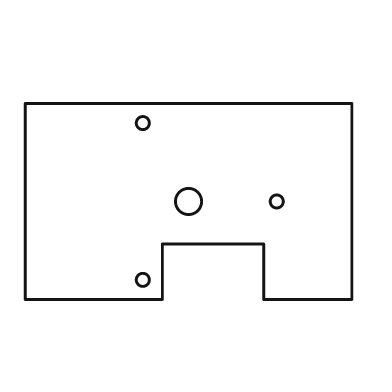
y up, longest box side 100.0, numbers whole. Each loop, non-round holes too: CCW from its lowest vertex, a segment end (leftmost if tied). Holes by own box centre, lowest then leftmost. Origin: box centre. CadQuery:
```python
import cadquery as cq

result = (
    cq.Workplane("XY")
    .moveTo(-50.0, -30.0)
    .lineTo(-8.0, -30.0)
    .lineTo(-8.0, -13.0)
    .lineTo(23.0, -13.0)
    .lineTo(23.0, -30.0)
    .lineTo(50.0, -30.0)
    .lineTo(50.0, 30.0)
    .lineTo(-50.0, 30.0)
    .close()
    .moveTo(-14.0, -24.0)
    .circle(2.0)
    .moveTo(0.0, 0.0)
    .circle(4.0)
    .moveTo(27.0, 0.0)
    .circle(2.0)
    .moveTo(-14.0, 24.0)
    .circle(2.0)
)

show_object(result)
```